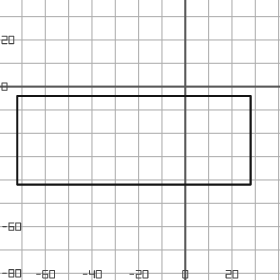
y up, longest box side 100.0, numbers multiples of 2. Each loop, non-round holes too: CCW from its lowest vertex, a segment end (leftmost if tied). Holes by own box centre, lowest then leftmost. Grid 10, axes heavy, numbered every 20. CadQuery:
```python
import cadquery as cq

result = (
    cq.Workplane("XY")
    .moveTo(-72.0, -42.0)
    .lineTo(28.0, -42.0)
    .lineTo(28.0, -4.0)
    .lineTo(-72.0, -4.0)
    .close()
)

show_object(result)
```